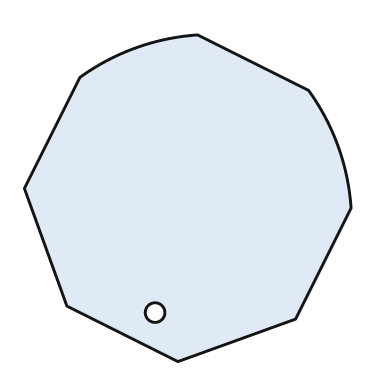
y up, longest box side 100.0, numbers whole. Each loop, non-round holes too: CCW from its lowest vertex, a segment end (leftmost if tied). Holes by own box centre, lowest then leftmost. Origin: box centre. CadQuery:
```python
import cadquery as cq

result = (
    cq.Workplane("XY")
    .moveTo(-3.0, -50.0)
    .lineTo(33.0, -37.0)
    .lineTo(50.0, -3.0)
    .threePointArc((46.0, 16.0), (37.0, 33.0))
    .lineTo(3.0, 50.0)
    .threePointArc((-16.0, 46.0), (-33.0, 37.0))
    .lineTo(-50.0, 3.0)
    .lineTo(-37.0, -33.0)
    .close()
    .moveTo(-10.0, -35.0)
    .circle(3.0)
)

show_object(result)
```